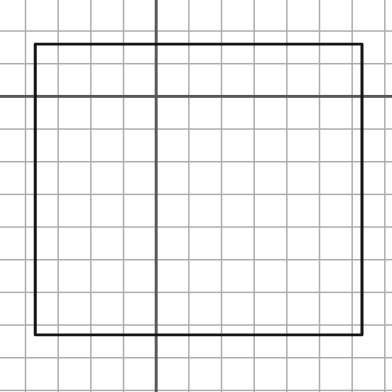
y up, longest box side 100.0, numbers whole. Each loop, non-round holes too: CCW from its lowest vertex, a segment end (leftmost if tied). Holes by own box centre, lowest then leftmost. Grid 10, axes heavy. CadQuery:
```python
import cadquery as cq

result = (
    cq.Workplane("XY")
    .moveTo(-37.0, -73.0)
    .lineTo(63.0, -73.0)
    .lineTo(63.0, 16.0)
    .lineTo(-37.0, 16.0)
    .close()
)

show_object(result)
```